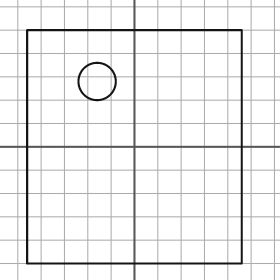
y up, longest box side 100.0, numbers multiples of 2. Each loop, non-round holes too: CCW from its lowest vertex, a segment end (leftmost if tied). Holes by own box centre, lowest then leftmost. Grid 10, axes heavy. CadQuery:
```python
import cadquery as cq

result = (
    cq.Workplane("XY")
    .moveTo(-46.0, -50.0)
    .lineTo(46.0, -50.0)
    .lineTo(46.0, 50.0)
    .lineTo(-46.0, 50.0)
    .close()
    .moveTo(-16.0, 28.0)
    .circle(8.0)
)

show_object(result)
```